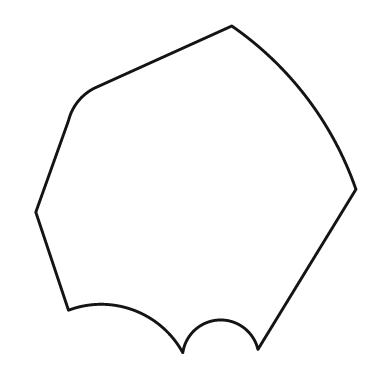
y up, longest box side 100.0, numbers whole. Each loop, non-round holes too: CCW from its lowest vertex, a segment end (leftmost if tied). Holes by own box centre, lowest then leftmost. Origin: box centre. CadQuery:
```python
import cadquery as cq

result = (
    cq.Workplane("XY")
    .moveTo(-4.0, -50.0)
    .threePointArc((7.0, -40.0), (19.0, -49.0))
    .lineTo(49.0, 0.0)
    .threePointArc((34.0, 28.0), (11.0, 50.0))
    .lineTo(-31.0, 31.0)
    .threePointArc((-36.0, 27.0), (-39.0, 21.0))
    .lineTo(-49.0, -7.0)
    .lineTo(-39.0, -37.0)
    .threePointArc((-19.0, -37.0), (-4.0, -50.0))
    .close()
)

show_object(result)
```